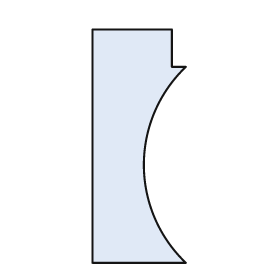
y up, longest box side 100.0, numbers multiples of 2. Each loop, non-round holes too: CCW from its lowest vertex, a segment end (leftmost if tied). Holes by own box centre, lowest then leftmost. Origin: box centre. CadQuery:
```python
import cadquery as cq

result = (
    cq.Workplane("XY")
    .moveTo(-20.0, -50.0)
    .lineTo(20.0, -50.0)
    .threePointArc((2.0, -8.0), (20.0, 34.0))
    .lineTo(14.0, 34.0)
    .lineTo(14.0, 50.0)
    .lineTo(-20.0, 50.0)
    .close()
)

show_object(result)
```